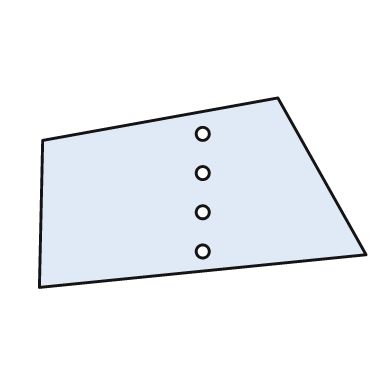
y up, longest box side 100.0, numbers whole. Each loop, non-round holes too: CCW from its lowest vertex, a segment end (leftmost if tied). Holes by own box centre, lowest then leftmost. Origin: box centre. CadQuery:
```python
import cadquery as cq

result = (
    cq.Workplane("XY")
    .moveTo(-50.0, -29.0)
    .lineTo(50.0, -19.0)
    .lineTo(23.0, 29.0)
    .lineTo(-49.0, 16.0)
    .close()
    .moveTo(0.0, -18.0)
    .circle(2.0)
    .moveTo(0.0, -6.0)
    .circle(2.0)
    .moveTo(0.0, 6.0)
    .circle(2.0)
    .moveTo(0.0, 18.0)
    .circle(2.0)
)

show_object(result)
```